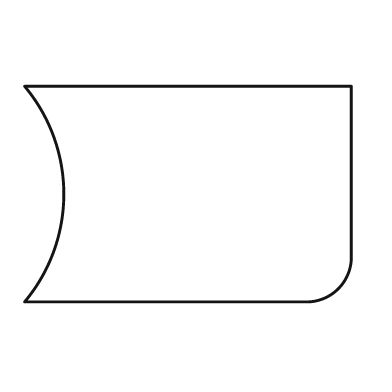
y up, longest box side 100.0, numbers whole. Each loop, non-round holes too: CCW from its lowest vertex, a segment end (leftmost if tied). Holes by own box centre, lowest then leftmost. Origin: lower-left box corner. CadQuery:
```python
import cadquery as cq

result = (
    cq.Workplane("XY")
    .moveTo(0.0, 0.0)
    .lineTo(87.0, 0.0)
    .threePointArc((96.0, 4.0), (100.0, 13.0))
    .lineTo(100.0, 66.0)
    .lineTo(0.0, 66.0)
    .threePointArc((12.0, 33.0), (0.0, 0.0))
    .close()
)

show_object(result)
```